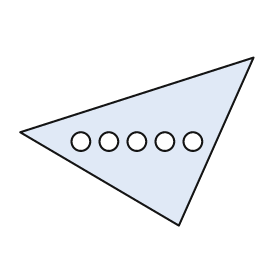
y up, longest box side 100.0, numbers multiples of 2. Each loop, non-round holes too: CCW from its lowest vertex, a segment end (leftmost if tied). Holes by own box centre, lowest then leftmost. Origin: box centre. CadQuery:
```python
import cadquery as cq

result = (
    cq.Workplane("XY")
    .moveTo(18.0, -36.0)
    .lineTo(50.0, 36.0)
    .lineTo(-50.0, 4.0)
    .close()
    .moveTo(-24.0, 0.0)
    .circle(4.0)
    .moveTo(-12.0, 0.0)
    .circle(4.0)
    .moveTo(0.0, 0.0)
    .circle(4.0)
    .moveTo(12.0, 0.0)
    .circle(4.0)
    .moveTo(24.0, 0.0)
    .circle(4.0)
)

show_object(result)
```